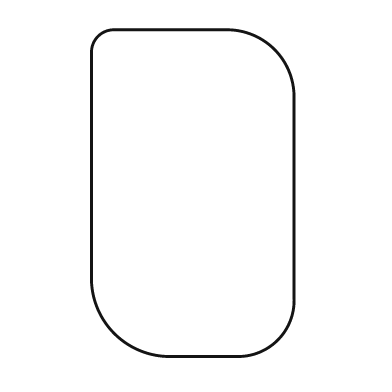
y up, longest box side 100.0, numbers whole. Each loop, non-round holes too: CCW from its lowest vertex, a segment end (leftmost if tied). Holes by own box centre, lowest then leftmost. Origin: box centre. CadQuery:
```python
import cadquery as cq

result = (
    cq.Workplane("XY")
    .moveTo(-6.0, -50.0)
    .lineTo(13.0, -50.0)
    .threePointArc((26.0, -45.0), (31.0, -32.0))
    .lineTo(31.0, 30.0)
    .threePointArc((25.0, 44.0), (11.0, 50.0))
    .lineTo(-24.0, 50.0)
    .threePointArc((-29.0, 48.0), (-31.0, 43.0))
    .lineTo(-31.0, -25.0)
    .threePointArc((-24.0, -43.0), (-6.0, -50.0))
    .close()
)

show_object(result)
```